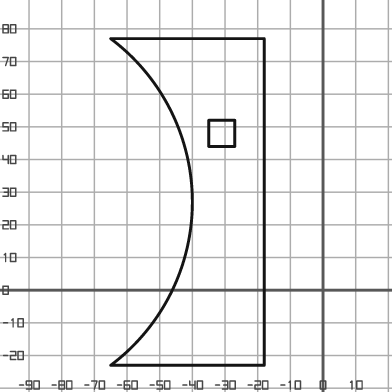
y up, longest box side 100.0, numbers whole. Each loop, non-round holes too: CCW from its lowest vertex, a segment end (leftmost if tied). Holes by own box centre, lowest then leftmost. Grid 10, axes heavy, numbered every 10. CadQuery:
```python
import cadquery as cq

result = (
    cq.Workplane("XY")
    .moveTo(-65.0, -23.0)
    .lineTo(-18.0, -23.0)
    .lineTo(-18.0, 77.0)
    .lineTo(-65.0, 77.0)
    .threePointArc((-40.0, 27.0), (-65.0, -23.0))
    .close()
    .moveTo(-35.0, 44.0)
    .lineTo(-27.0, 44.0)
    .lineTo(-27.0, 52.0)
    .lineTo(-35.0, 52.0)
    .close()
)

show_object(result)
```